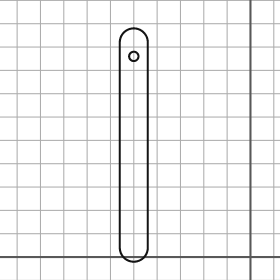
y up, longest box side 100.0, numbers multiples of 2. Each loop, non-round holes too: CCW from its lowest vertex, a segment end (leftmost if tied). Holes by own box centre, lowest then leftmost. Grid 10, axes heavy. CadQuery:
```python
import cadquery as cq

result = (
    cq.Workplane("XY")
    .moveTo(-56.0, 4.0)
    .threePointArc((-50.0, -2.0), (-44.0, 4.0))
    .lineTo(-44.0, 92.0)
    .threePointArc((-50.0, 98.0), (-56.0, 92.0))
    .close()
    .moveTo(-50.0, 86.0)
    .circle(2.0)
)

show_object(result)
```